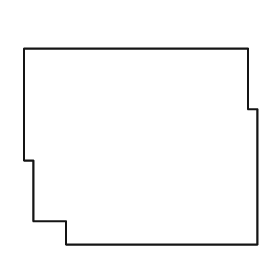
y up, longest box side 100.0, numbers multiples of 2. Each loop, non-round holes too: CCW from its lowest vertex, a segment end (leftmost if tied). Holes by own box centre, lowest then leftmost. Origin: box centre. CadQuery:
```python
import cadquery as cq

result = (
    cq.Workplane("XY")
    .moveTo(-32.0, -42.0)
    .lineTo(50.0, -42.0)
    .lineTo(50.0, 16.0)
    .lineTo(46.0, 16.0)
    .lineTo(46.0, 42.0)
    .lineTo(-50.0, 42.0)
    .lineTo(-50.0, -6.0)
    .lineTo(-46.0, -6.0)
    .lineTo(-46.0, -32.0)
    .lineTo(-32.0, -32.0)
    .close()
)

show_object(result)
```